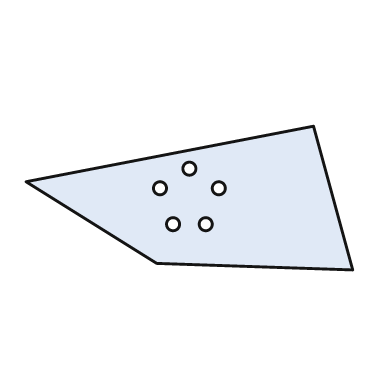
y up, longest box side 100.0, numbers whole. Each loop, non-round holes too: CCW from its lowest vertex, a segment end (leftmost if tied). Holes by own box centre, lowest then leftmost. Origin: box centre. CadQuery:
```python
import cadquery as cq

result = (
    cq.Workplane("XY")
    .moveTo(50.0, -22.0)
    .lineTo(38.0, 22.0)
    .lineTo(-50.0, 5.0)
    .lineTo(-10.0, -20.0)
    .close()
    .moveTo(-5.0, -8.0)
    .circle(2.0)
    .moveTo(5.0, -8.0)
    .circle(2.0)
    .moveTo(-9.0, 3.0)
    .circle(2.0)
    .moveTo(9.0, 3.0)
    .circle(2.0)
    .moveTo(0.0, 9.0)
    .circle(2.0)
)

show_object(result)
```